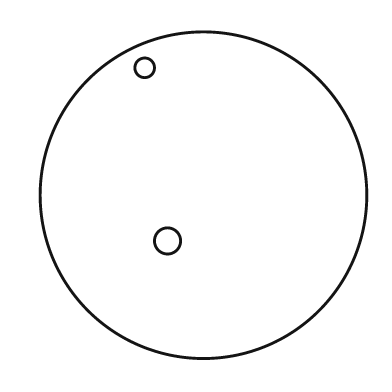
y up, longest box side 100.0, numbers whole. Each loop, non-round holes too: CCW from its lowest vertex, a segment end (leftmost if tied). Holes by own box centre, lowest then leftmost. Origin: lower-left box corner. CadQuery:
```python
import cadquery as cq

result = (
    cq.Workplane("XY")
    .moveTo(50.0, 50.0)
    .circle(50.0)
    .moveTo(39.0, 36.0)
    .circle(4.0)
    .moveTo(32.0, 89.0)
    .circle(3.0)
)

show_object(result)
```